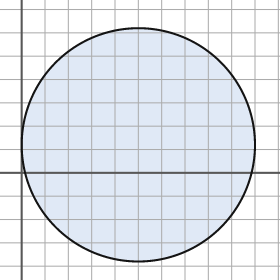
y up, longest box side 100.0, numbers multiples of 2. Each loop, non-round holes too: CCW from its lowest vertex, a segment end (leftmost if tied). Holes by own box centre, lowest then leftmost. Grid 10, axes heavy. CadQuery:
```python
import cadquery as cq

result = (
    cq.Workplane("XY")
    .moveTo(50.0, 12.0)
    .circle(50.0)
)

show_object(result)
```